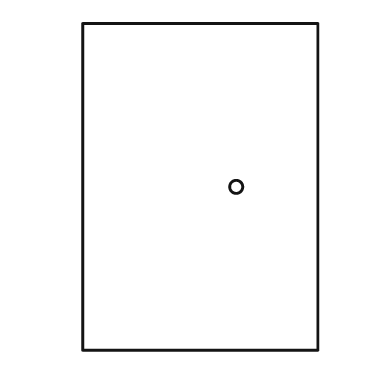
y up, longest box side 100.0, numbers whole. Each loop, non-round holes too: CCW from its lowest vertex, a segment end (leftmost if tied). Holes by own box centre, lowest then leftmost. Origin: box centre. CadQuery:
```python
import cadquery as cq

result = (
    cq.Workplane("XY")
    .moveTo(-36.0, -50.0)
    .lineTo(36.0, -50.0)
    .lineTo(36.0, 50.0)
    .lineTo(-36.0, 50.0)
    .close()
    .moveTo(11.0, 0.0)
    .circle(2.0)
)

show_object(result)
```